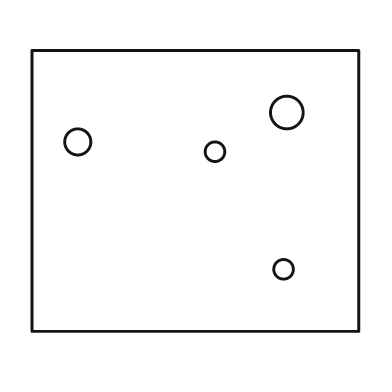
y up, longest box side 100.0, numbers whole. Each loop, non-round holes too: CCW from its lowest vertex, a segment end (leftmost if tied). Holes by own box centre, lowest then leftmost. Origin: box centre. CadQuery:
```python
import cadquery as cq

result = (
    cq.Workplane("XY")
    .moveTo(-50.0, -43.0)
    .lineTo(50.0, -43.0)
    .lineTo(50.0, 43.0)
    .lineTo(-50.0, 43.0)
    .close()
    .moveTo(27.0, -24.0)
    .circle(3.0)
    .moveTo(6.0, 12.0)
    .circle(3.0)
    .moveTo(-36.0, 15.0)
    .circle(4.0)
    .moveTo(28.0, 24.0)
    .circle(5.0)
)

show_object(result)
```